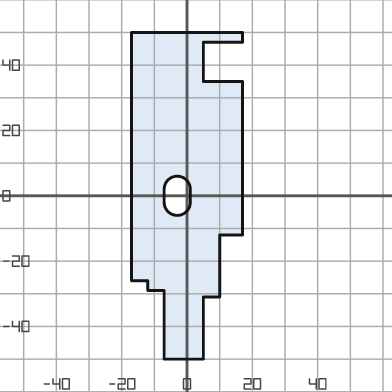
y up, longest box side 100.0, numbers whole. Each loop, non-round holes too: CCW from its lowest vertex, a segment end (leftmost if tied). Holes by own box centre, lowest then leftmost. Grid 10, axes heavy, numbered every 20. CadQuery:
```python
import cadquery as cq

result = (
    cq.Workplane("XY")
    .moveTo(-7.0, -50.0)
    .lineTo(5.0, -50.0)
    .lineTo(5.0, -31.0)
    .lineTo(10.0, -31.0)
    .lineTo(10.0, -12.0)
    .lineTo(17.0, -12.0)
    .lineTo(17.0, 35.0)
    .lineTo(5.0, 35.0)
    .lineTo(5.0, 47.0)
    .lineTo(17.0, 47.0)
    .lineTo(17.0, 50.0)
    .lineTo(-17.0, 50.0)
    .lineTo(-17.0, -26.0)
    .lineTo(-12.0, -26.0)
    .lineTo(-12.0, -29.0)
    .lineTo(-7.0, -29.0)
    .close()
    .moveTo(-7.0, -2.0)
    .threePointArc((-3.0, -6.0), (1.0, -2.0))
    .lineTo(1.0, 2.0)
    .threePointArc((-3.0, 6.0), (-7.0, 2.0))
    .close()
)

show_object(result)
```